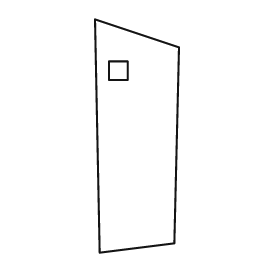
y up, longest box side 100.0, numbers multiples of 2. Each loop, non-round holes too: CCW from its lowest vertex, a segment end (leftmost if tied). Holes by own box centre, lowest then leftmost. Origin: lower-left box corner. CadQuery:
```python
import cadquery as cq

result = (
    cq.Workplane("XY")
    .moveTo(2.0, 0.0)
    .lineTo(34.0, 4.0)
    .lineTo(36.0, 88.0)
    .lineTo(0.0, 100.0)
    .close()
    .moveTo(6.0, 74.0)
    .lineTo(14.0, 74.0)
    .lineTo(14.0, 82.0)
    .lineTo(6.0, 82.0)
    .close()
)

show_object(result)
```